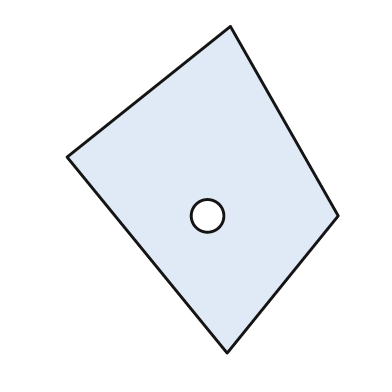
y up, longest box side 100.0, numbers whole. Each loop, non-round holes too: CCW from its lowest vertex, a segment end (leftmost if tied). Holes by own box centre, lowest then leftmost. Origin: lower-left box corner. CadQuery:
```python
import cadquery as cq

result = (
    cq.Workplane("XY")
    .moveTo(49.0, 0.0)
    .lineTo(83.0, 42.0)
    .lineTo(50.0, 100.0)
    .lineTo(0.0, 60.0)
    .close()
    .moveTo(43.0, 42.0)
    .circle(5.0)
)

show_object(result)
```